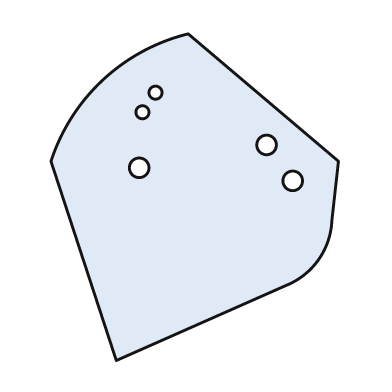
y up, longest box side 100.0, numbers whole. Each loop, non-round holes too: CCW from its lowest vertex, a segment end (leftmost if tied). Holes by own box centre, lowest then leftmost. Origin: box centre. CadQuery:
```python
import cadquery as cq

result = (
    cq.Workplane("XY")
    .moveTo(-24.0, -50.0)
    .lineTo(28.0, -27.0)
    .threePointArc((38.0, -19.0), (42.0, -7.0))
    .lineTo(44.0, 11.0)
    .lineTo(-2.0, 50.0)
    .threePointArc((-28.0, 36.0), (-44.0, 11.0))
    .close()
    .moveTo(30.0, 5.0)
    .circle(3.0)
    .moveTo(-17.0, 9.0)
    .circle(3.0)
    .moveTo(22.0, 16.0)
    .circle(3.0)
    .moveTo(-16.0, 26.0)
    .circle(2.0)
    .moveTo(-12.0, 32.0)
    .circle(2.0)
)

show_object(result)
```